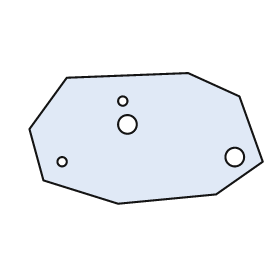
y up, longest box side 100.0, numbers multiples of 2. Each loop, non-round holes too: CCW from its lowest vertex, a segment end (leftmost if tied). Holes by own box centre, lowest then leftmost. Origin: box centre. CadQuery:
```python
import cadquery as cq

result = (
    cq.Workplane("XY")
    .moveTo(-12.0, -28.0)
    .lineTo(30.0, -24.0)
    .lineTo(50.0, -10.0)
    .lineTo(40.0, 18.0)
    .lineTo(18.0, 28.0)
    .lineTo(-34.0, 26.0)
    .lineTo(-50.0, 4.0)
    .lineTo(-44.0, -18.0)
    .close()
    .moveTo(-36.0, -10.0)
    .circle(2.0)
    .moveTo(38.0, -8.0)
    .circle(4.0)
    .moveTo(-8.0, 6.0)
    .circle(4.0)
    .moveTo(-10.0, 16.0)
    .circle(2.0)
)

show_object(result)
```